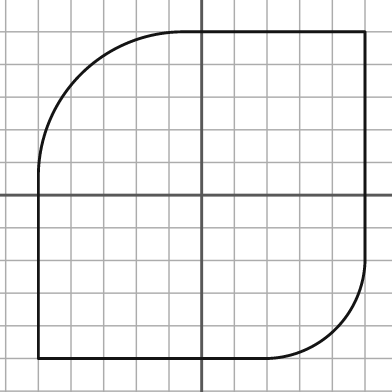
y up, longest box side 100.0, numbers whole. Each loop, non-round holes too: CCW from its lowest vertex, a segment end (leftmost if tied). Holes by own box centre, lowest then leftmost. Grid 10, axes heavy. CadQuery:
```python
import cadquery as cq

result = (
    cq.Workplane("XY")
    .moveTo(-50.0, -50.0)
    .lineTo(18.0, -50.0)
    .threePointArc((41.0, -41.0), (50.0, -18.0))
    .lineTo(50.0, 50.0)
    .lineTo(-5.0, 50.0)
    .threePointArc((-37.0, 37.0), (-50.0, 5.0))
    .close()
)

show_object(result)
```